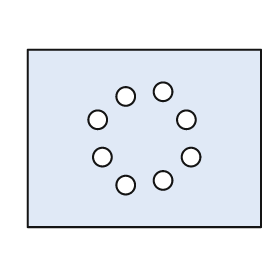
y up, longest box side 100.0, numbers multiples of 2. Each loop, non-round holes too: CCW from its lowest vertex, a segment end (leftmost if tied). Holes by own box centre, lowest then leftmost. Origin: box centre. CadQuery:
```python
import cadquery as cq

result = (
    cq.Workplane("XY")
    .moveTo(-50.0, -38.0)
    .lineTo(50.0, -38.0)
    .lineTo(50.0, 38.0)
    .lineTo(-50.0, 38.0)
    .close()
    .moveTo(-8.0, -20.0)
    .circle(4.0)
    .moveTo(8.0, -18.0)
    .circle(4.0)
    .moveTo(-18.0, -8.0)
    .circle(4.0)
    .moveTo(20.0, -8.0)
    .circle(4.0)
    .moveTo(-20.0, 8.0)
    .circle(4.0)
    .moveTo(18.0, 8.0)
    .circle(4.0)
    .moveTo(-8.0, 18.0)
    .circle(4.0)
    .moveTo(8.0, 20.0)
    .circle(4.0)
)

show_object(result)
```